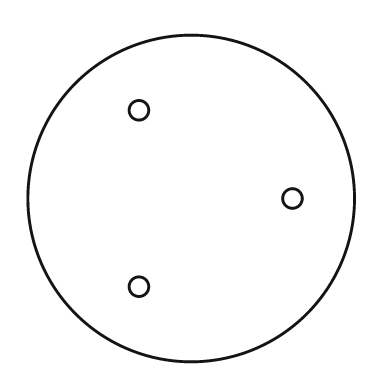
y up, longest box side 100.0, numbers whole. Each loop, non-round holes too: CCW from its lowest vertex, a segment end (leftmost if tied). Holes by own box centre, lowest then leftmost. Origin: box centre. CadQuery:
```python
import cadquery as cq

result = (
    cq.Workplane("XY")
    .moveTo(0.0, 0.0)
    .circle(50.0)
    .moveTo(-16.0, -27.0)
    .circle(3.0)
    .moveTo(31.0, 0.0)
    .circle(3.0)
    .moveTo(-16.0, 27.0)
    .circle(3.0)
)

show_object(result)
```